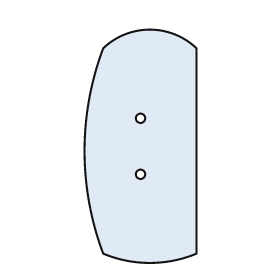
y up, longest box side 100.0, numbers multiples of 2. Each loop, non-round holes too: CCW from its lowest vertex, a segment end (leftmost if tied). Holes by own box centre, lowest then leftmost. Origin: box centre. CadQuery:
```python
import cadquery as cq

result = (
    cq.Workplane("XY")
    .moveTo(-16.0, -46.0)
    .threePointArc((4.0, -50.0), (24.0, -46.0))
    .lineTo(24.0, 42.0)
    .threePointArc((4.0, 50.0), (-16.0, 42.0))
    .threePointArc((-24.0, -2.0), (-16.0, -46.0))
    .close()
    .moveTo(0.0, -12.0)
    .circle(2.0)
    .moveTo(0.0, 12.0)
    .circle(2.0)
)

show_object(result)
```